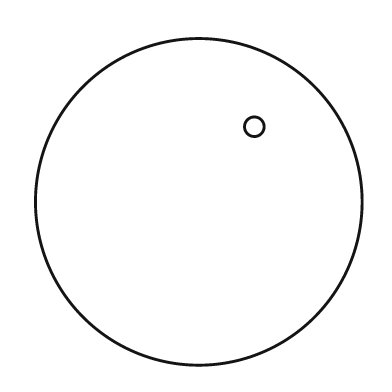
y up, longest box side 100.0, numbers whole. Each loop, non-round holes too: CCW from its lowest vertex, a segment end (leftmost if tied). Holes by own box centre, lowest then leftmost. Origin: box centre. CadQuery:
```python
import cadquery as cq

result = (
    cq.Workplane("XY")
    .moveTo(0.0, 0.0)
    .circle(50.0)
    .moveTo(17.0, 23.0)
    .circle(3.0)
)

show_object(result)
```